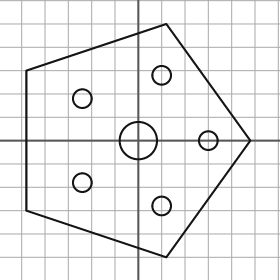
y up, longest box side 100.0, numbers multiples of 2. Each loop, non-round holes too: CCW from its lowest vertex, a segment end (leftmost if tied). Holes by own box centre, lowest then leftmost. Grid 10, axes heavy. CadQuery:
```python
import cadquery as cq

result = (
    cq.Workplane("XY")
    .moveTo(12.0, -50.0)
    .lineTo(48.0, 0.0)
    .lineTo(12.0, 50.0)
    .lineTo(-48.0, 30.0)
    .lineTo(-48.0, -30.0)
    .close()
    .moveTo(10.0, -28.0)
    .circle(4.0)
    .moveTo(-24.0, -18.0)
    .circle(4.0)
    .moveTo(0.0, 0.0)
    .circle(8.0)
    .moveTo(30.0, 0.0)
    .circle(4.0)
    .moveTo(-24.0, 18.0)
    .circle(4.0)
    .moveTo(10.0, 28.0)
    .circle(4.0)
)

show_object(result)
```